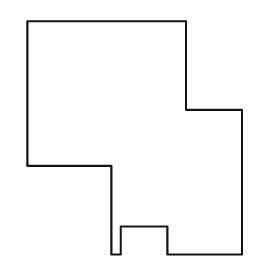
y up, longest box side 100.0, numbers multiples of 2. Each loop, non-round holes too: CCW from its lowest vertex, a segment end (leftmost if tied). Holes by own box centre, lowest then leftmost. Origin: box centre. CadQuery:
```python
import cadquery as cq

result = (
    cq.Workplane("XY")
    .moveTo(-10.0, -50.0)
    .lineTo(-6.0, -50.0)
    .lineTo(-6.0, -38.0)
    .lineTo(14.0, -38.0)
    .lineTo(14.0, -50.0)
    .lineTo(46.0, -50.0)
    .lineTo(46.0, 12.0)
    .lineTo(22.0, 12.0)
    .lineTo(22.0, 50.0)
    .lineTo(-46.0, 50.0)
    .lineTo(-46.0, -12.0)
    .lineTo(-10.0, -12.0)
    .close()
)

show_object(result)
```